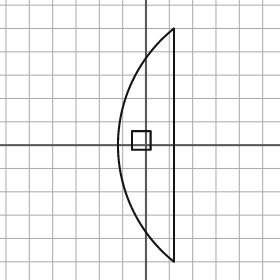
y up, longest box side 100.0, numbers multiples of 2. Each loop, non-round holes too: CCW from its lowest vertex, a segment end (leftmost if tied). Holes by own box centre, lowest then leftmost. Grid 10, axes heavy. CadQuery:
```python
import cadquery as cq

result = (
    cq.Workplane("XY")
    .moveTo(12.0, -50.0)
    .lineTo(12.0, 50.0)
    .threePointArc((-12.0, 0.0), (12.0, -50.0))
    .close()
    .moveTo(-6.0, -2.0)
    .lineTo(2.0, -2.0)
    .lineTo(2.0, 6.0)
    .lineTo(-6.0, 6.0)
    .close()
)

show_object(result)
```